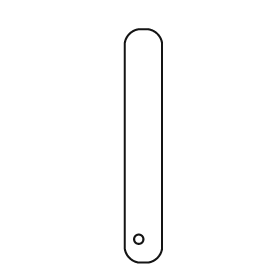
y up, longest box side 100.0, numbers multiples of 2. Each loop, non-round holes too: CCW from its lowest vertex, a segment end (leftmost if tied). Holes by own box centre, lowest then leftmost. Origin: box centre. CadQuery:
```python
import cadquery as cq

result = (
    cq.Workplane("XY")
    .moveTo(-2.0, -50.0)
    .lineTo(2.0, -50.0)
    .threePointArc((6.0, -48.0), (8.0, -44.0))
    .lineTo(8.0, 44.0)
    .threePointArc((6.0, 48.0), (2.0, 50.0))
    .lineTo(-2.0, 50.0)
    .threePointArc((-6.0, 48.0), (-8.0, 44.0))
    .lineTo(-8.0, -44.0)
    .threePointArc((-6.0, -48.0), (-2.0, -50.0))
    .close()
    .moveTo(-2.0, -40.0)
    .circle(2.0)
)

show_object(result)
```